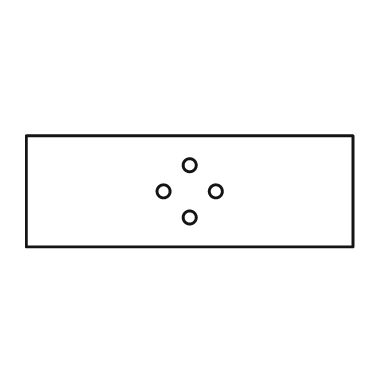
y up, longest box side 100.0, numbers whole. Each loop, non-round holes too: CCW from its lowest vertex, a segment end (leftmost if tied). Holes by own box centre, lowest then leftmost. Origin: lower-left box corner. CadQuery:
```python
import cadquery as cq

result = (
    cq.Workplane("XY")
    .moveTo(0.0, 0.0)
    .lineTo(100.0, 0.0)
    .lineTo(100.0, 34.0)
    .lineTo(0.0, 34.0)
    .close()
    .moveTo(50.0, 9.0)
    .circle(2.0)
    .moveTo(42.0, 17.0)
    .circle(2.0)
    .moveTo(58.0, 17.0)
    .circle(2.0)
    .moveTo(50.0, 25.0)
    .circle(2.0)
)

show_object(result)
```